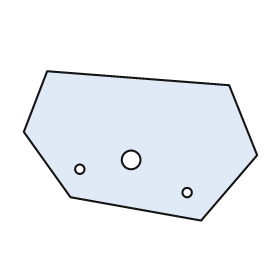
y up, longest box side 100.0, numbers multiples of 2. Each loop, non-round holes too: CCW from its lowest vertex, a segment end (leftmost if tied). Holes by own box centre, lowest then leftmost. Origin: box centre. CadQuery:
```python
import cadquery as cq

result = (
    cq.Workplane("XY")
    .moveTo(26.0, -32.0)
    .lineTo(50.0, -4.0)
    .lineTo(38.0, 26.0)
    .lineTo(-40.0, 32.0)
    .lineTo(-50.0, 6.0)
    .lineTo(-30.0, -22.0)
    .close()
    .moveTo(20.0, -20.0)
    .circle(2.0)
    .moveTo(-26.0, -10.0)
    .circle(2.0)
    .moveTo(-4.0, -6.0)
    .circle(4.0)
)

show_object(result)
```